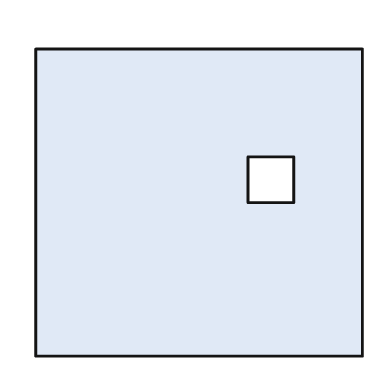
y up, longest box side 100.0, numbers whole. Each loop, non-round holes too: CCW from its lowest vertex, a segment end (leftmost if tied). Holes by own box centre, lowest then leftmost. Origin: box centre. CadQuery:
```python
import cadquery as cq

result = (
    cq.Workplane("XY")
    .moveTo(-50.0, -47.0)
    .lineTo(50.0, -47.0)
    .lineTo(50.0, 47.0)
    .lineTo(-50.0, 47.0)
    .close()
    .moveTo(15.0, 0.0)
    .lineTo(29.0, 0.0)
    .lineTo(29.0, 14.0)
    .lineTo(15.0, 14.0)
    .close()
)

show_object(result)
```